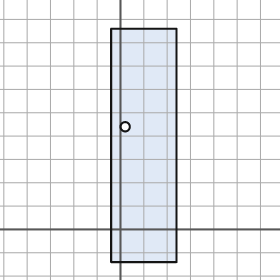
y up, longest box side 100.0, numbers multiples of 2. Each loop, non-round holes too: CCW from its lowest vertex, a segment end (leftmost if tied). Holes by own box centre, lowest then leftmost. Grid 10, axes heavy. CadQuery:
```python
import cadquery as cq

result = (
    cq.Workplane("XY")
    .moveTo(-4.0, -14.0)
    .lineTo(24.0, -14.0)
    .lineTo(24.0, 86.0)
    .lineTo(-4.0, 86.0)
    .close()
    .moveTo(2.0, 44.0)
    .circle(2.0)
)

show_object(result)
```